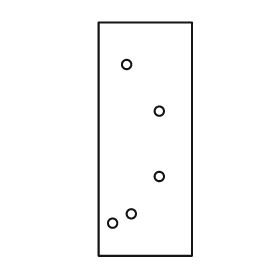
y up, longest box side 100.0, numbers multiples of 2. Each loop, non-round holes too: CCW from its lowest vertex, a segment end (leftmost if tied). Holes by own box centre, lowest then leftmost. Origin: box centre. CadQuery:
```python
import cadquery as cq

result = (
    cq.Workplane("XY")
    .moveTo(-20.0, -50.0)
    .lineTo(20.0, -50.0)
    .lineTo(20.0, 50.0)
    .lineTo(-20.0, 50.0)
    .close()
    .moveTo(-14.0, -36.0)
    .circle(2.0)
    .moveTo(-6.0, -32.0)
    .circle(2.0)
    .moveTo(6.0, -16.0)
    .circle(2.0)
    .moveTo(6.0, 12.0)
    .circle(2.0)
    .moveTo(-8.0, 32.0)
    .circle(2.0)
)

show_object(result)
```